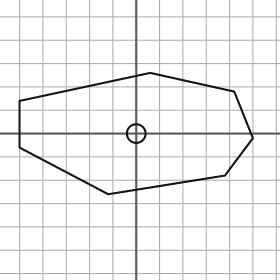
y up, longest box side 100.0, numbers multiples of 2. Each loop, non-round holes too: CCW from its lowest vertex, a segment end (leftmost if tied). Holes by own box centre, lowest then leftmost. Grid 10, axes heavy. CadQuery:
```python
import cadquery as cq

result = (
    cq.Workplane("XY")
    .moveTo(-12.0, -26.0)
    .lineTo(38.0, -18.0)
    .lineTo(50.0, -2.0)
    .lineTo(42.0, 18.0)
    .lineTo(6.0, 26.0)
    .lineTo(-50.0, 14.0)
    .lineTo(-50.0, -6.0)
    .close()
    .moveTo(0.0, 0.0)
    .circle(4.0)
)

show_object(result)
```